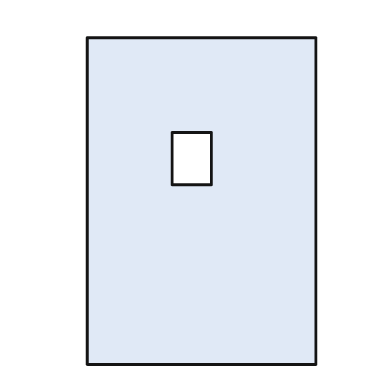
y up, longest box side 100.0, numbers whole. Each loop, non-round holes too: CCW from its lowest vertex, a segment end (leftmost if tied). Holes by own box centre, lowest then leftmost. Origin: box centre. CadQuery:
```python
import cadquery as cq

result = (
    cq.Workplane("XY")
    .moveTo(-35.0, -50.0)
    .lineTo(35.0, -50.0)
    .lineTo(35.0, 50.0)
    .lineTo(-35.0, 50.0)
    .close()
    .moveTo(-9.0, 5.0)
    .lineTo(3.0, 5.0)
    .lineTo(3.0, 21.0)
    .lineTo(-9.0, 21.0)
    .close()
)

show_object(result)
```